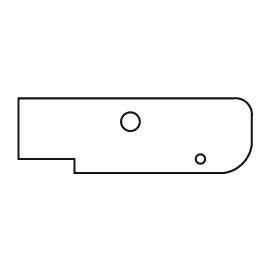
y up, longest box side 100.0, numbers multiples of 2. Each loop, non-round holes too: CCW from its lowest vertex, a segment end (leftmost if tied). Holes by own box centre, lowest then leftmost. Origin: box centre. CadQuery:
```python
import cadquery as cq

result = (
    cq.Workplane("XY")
    .moveTo(-26.0, -16.0)
    .lineTo(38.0, -16.0)
    .threePointArc((46.0, -12.0), (50.0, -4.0))
    .lineTo(50.0, 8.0)
    .threePointArc((48.0, 14.0), (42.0, 16.0))
    .lineTo(-50.0, 16.0)
    .lineTo(-50.0, -10.0)
    .lineTo(-26.0, -10.0)
    .close()
    .moveTo(28.0, -10.0)
    .circle(2.0)
    .moveTo(-2.0, 6.0)
    .circle(4.0)
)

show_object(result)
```